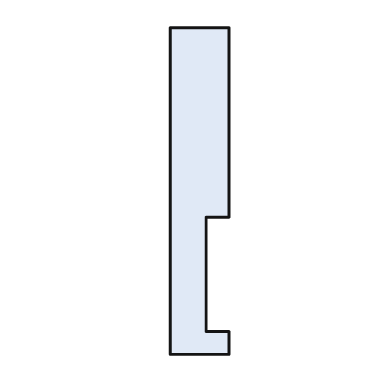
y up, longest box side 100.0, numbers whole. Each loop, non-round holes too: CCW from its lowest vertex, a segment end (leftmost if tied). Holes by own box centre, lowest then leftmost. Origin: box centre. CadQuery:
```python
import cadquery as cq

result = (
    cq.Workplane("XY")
    .moveTo(-9.0, -50.0)
    .lineTo(9.0, -50.0)
    .lineTo(9.0, -43.0)
    .lineTo(2.0, -43.0)
    .lineTo(2.0, -8.0)
    .lineTo(9.0, -8.0)
    .lineTo(9.0, 50.0)
    .lineTo(-9.0, 50.0)
    .close()
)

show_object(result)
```